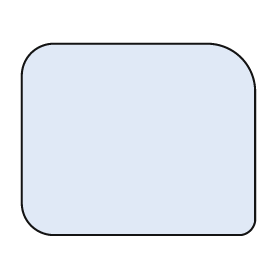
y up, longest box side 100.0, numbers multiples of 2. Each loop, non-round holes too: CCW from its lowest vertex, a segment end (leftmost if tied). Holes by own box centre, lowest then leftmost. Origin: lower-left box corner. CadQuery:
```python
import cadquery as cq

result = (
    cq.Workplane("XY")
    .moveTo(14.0, 0.0)
    .lineTo(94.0, 0.0)
    .threePointArc((98.0, 2.0), (100.0, 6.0))
    .lineTo(100.0, 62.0)
    .threePointArc((94.0, 76.0), (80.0, 82.0))
    .lineTo(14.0, 82.0)
    .threePointArc((4.0, 78.0), (0.0, 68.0))
    .lineTo(0.0, 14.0)
    .threePointArc((4.0, 4.0), (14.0, 0.0))
    .close()
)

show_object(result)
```